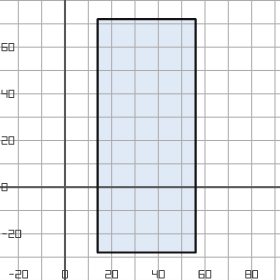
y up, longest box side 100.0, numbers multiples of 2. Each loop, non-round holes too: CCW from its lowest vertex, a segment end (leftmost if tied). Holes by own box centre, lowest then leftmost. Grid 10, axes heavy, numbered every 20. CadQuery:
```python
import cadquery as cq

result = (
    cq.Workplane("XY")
    .moveTo(14.0, -28.0)
    .lineTo(56.0, -28.0)
    .lineTo(56.0, 72.0)
    .lineTo(14.0, 72.0)
    .close()
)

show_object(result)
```